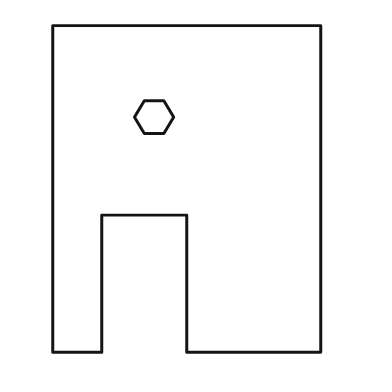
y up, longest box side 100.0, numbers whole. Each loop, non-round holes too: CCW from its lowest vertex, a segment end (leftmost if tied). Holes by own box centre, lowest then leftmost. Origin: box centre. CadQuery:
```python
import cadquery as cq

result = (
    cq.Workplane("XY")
    .moveTo(-41.0, -50.0)
    .lineTo(-26.0, -50.0)
    .lineTo(-26.0, -8.0)
    .lineTo(0.0, -8.0)
    .lineTo(0.0, -50.0)
    .lineTo(41.0, -50.0)
    .lineTo(41.0, 50.0)
    .lineTo(-41.0, 50.0)
    .close()
    .moveTo(-13.0, 17.0)
    .lineTo(-7.0, 17.0)
    .lineTo(-4.0, 22.0)
    .lineTo(-7.0, 27.0)
    .lineTo(-13.0, 27.0)
    .lineTo(-16.0, 22.0)
    .close()
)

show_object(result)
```